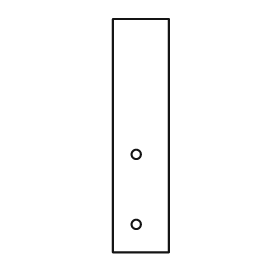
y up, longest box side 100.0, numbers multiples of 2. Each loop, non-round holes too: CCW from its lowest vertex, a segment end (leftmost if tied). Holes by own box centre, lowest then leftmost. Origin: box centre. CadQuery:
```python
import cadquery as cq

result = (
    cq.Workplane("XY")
    .moveTo(-12.0, -50.0)
    .lineTo(12.0, -50.0)
    .lineTo(12.0, 50.0)
    .lineTo(-12.0, 50.0)
    .close()
    .moveTo(-2.0, -38.0)
    .circle(2.0)
    .moveTo(-2.0, -8.0)
    .circle(2.0)
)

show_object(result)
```